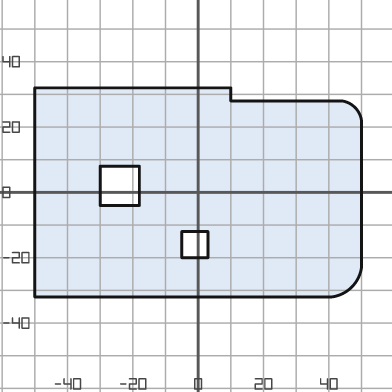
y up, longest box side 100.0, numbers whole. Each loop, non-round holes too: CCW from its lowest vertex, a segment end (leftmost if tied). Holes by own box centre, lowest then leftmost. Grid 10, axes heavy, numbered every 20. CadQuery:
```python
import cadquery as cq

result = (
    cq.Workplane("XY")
    .moveTo(-50.0, -32.0)
    .lineTo(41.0, -32.0)
    .threePointArc((47.0, -29.0), (50.0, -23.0))
    .lineTo(50.0, 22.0)
    .threePointArc((48.0, 26.0), (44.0, 28.0))
    .lineTo(10.0, 28.0)
    .lineTo(10.0, 32.0)
    .lineTo(-50.0, 32.0)
    .close()
    .moveTo(-5.0, -20.0)
    .lineTo(3.0, -20.0)
    .lineTo(3.0, -12.0)
    .lineTo(-5.0, -12.0)
    .close()
    .moveTo(-30.0, -4.0)
    .lineTo(-18.0, -4.0)
    .lineTo(-18.0, 8.0)
    .lineTo(-30.0, 8.0)
    .close()
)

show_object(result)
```